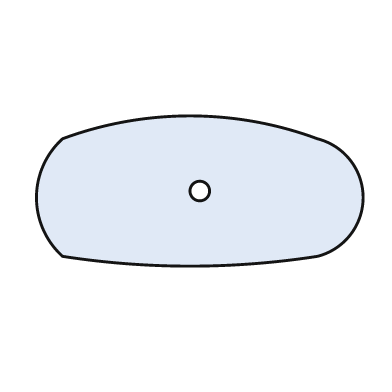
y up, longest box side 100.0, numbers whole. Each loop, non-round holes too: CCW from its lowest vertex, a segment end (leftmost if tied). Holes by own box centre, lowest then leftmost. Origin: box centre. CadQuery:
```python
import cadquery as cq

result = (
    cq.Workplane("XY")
    .moveTo(-42.0, -20.0)
    .threePointArc((-3.0, -23.0), (36.0, -20.0))
    .threePointArc((50.0, -2.0), (36.0, 16.0))
    .threePointArc((-3.0, 23.0), (-42.0, 16.0))
    .threePointArc((-50.0, -2.0), (-42.0, -20.0))
    .close()
    .moveTo(0.0, 0.0)
    .circle(3.0)
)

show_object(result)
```